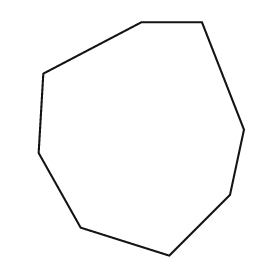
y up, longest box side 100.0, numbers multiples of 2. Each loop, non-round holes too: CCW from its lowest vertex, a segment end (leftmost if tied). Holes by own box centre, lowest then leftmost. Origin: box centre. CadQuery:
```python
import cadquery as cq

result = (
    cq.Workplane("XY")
    .moveTo(12.0, -50.0)
    .lineTo(38.0, -24.0)
    .lineTo(44.0, 4.0)
    .lineTo(26.0, 50.0)
    .lineTo(0.0, 50.0)
    .lineTo(-42.0, 28.0)
    .lineTo(-44.0, -6.0)
    .lineTo(-26.0, -38.0)
    .close()
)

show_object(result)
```